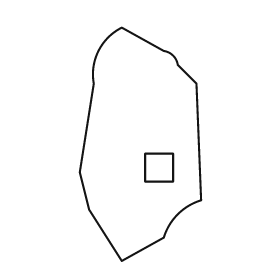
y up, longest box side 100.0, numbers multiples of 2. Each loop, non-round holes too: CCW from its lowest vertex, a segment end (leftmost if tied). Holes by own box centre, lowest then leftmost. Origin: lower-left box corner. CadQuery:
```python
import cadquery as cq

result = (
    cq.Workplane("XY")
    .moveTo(18.0, 0.0)
    .lineTo(36.0, 10.0)
    .threePointArc((42.0, 20.0), (52.0, 26.0))
    .lineTo(50.0, 76.0)
    .lineTo(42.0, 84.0)
    .threePointArc((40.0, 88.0), (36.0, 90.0))
    .lineTo(18.0, 100.0)
    .threePointArc((8.0, 90.0), (6.0, 76.0))
    .lineTo(0.0, 38.0)
    .lineTo(4.0, 22.0)
    .close()
    .moveTo(28.0, 34.0)
    .lineTo(40.0, 34.0)
    .lineTo(40.0, 46.0)
    .lineTo(28.0, 46.0)
    .close()
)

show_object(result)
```